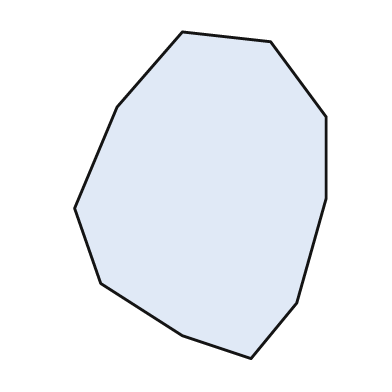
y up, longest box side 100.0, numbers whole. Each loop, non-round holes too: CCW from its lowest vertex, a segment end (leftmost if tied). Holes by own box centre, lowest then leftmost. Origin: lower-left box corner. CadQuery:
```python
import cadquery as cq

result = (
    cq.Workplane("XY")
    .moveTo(54.0, 0.0)
    .lineTo(68.0, 17.0)
    .lineTo(77.0, 49.0)
    .lineTo(77.0, 74.0)
    .lineTo(60.0, 97.0)
    .lineTo(33.0, 100.0)
    .lineTo(13.0, 77.0)
    .lineTo(0.0, 46.0)
    .lineTo(8.0, 23.0)
    .lineTo(33.0, 7.0)
    .close()
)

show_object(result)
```